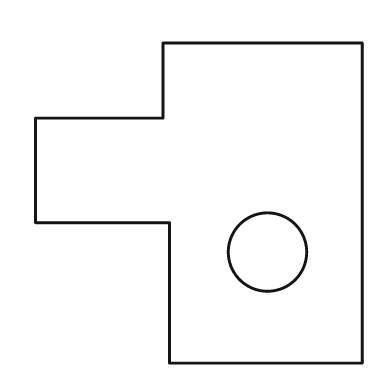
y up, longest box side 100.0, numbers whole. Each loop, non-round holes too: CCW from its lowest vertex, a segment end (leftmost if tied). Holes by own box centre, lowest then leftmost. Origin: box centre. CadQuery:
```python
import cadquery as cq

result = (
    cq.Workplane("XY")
    .moveTo(-9.0, -49.0)
    .lineTo(50.0, -49.0)
    .lineTo(50.0, 49.0)
    .lineTo(-11.0, 49.0)
    .lineTo(-11.0, 26.0)
    .lineTo(-50.0, 26.0)
    .lineTo(-50.0, -6.0)
    .lineTo(-9.0, -6.0)
    .close()
    .moveTo(21.0, -15.0)
    .circle(12.0)
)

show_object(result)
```